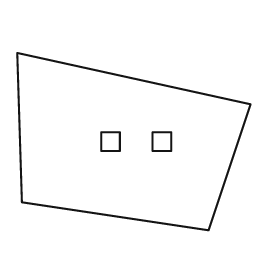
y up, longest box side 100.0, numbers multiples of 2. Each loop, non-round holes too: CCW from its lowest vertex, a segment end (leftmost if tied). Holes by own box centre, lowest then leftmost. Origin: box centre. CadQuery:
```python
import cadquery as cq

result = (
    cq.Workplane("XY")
    .moveTo(32.0, -38.0)
    .lineTo(50.0, 16.0)
    .lineTo(-50.0, 38.0)
    .lineTo(-48.0, -26.0)
    .close()
    .moveTo(-14.0, -4.0)
    .lineTo(-6.0, -4.0)
    .lineTo(-6.0, 4.0)
    .lineTo(-14.0, 4.0)
    .close()
    .moveTo(8.0, -4.0)
    .lineTo(16.0, -4.0)
    .lineTo(16.0, 4.0)
    .lineTo(8.0, 4.0)
    .close()
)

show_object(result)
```